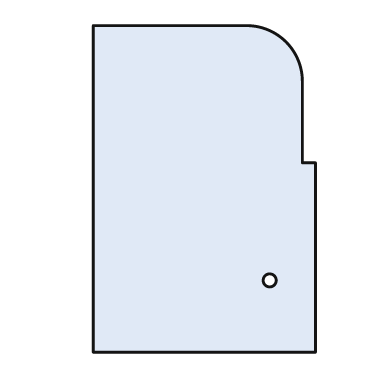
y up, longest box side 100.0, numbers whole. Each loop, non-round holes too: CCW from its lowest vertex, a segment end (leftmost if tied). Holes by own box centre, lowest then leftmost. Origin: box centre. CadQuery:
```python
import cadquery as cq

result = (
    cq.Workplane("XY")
    .moveTo(-34.0, -50.0)
    .lineTo(34.0, -50.0)
    .lineTo(34.0, 8.0)
    .lineTo(30.0, 8.0)
    .lineTo(30.0, 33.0)
    .threePointArc((25.0, 45.0), (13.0, 50.0))
    .lineTo(-34.0, 50.0)
    .close()
    .moveTo(20.0, -28.0)
    .circle(2.0)
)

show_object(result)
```